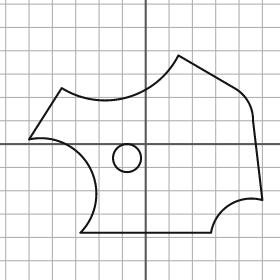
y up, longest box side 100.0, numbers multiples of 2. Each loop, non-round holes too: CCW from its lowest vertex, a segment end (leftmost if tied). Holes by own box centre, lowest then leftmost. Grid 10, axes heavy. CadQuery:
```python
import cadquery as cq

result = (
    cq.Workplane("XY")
    .moveTo(-28.0, -38.0)
    .lineTo(28.0, -38.0)
    .threePointArc((36.0, -26.0), (50.0, -24.0))
    .lineTo(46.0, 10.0)
    .threePointArc((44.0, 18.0), (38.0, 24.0))
    .lineTo(14.0, 38.0)
    .threePointArc((-8.0, 20.0), (-36.0, 24.0))
    .lineTo(-50.0, 2.0)
    .threePointArc((-24.0, -10.0), (-28.0, -38.0))
    .close()
    .moveTo(-8.0, -6.0)
    .circle(6.0)
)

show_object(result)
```